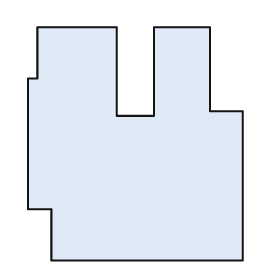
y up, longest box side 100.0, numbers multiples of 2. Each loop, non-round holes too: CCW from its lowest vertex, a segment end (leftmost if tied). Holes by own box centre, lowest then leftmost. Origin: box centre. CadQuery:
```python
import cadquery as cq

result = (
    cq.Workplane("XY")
    .moveTo(-36.0, -50.0)
    .lineTo(46.0, -50.0)
    .lineTo(46.0, 14.0)
    .lineTo(32.0, 14.0)
    .lineTo(32.0, 50.0)
    .lineTo(8.0, 50.0)
    .lineTo(8.0, 12.0)
    .lineTo(-8.0, 12.0)
    .lineTo(-8.0, 50.0)
    .lineTo(-42.0, 50.0)
    .lineTo(-42.0, 28.0)
    .lineTo(-46.0, 28.0)
    .lineTo(-46.0, -28.0)
    .lineTo(-36.0, -28.0)
    .close()
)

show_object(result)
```